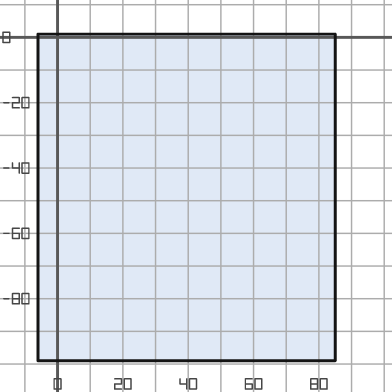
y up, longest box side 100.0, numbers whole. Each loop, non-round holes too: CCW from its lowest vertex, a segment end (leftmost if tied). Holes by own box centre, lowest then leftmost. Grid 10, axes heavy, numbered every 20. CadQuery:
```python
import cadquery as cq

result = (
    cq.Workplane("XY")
    .moveTo(-6.0, -99.0)
    .lineTo(85.0, -99.0)
    .lineTo(85.0, 1.0)
    .lineTo(-6.0, 1.0)
    .close()
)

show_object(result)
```